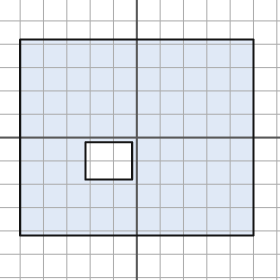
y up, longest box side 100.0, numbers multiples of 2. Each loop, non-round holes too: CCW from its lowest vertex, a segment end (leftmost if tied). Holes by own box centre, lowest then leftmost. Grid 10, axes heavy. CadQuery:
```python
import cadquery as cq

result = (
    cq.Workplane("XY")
    .moveTo(-50.0, -42.0)
    .lineTo(50.0, -42.0)
    .lineTo(50.0, 42.0)
    .lineTo(-50.0, 42.0)
    .close()
    .moveTo(-22.0, -18.0)
    .lineTo(-2.0, -18.0)
    .lineTo(-2.0, -2.0)
    .lineTo(-22.0, -2.0)
    .close()
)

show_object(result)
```